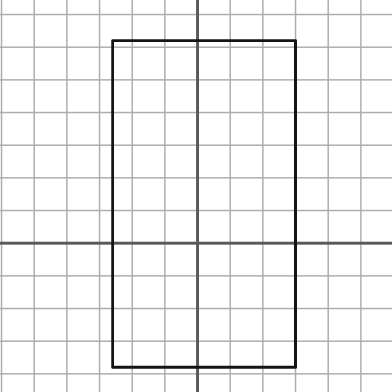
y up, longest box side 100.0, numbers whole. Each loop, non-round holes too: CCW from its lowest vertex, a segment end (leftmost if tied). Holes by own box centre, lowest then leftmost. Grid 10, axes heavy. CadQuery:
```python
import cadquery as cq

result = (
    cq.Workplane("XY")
    .moveTo(-26.0, -38.0)
    .lineTo(30.0, -38.0)
    .lineTo(30.0, 62.0)
    .lineTo(-26.0, 62.0)
    .close()
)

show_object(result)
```